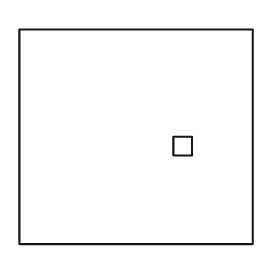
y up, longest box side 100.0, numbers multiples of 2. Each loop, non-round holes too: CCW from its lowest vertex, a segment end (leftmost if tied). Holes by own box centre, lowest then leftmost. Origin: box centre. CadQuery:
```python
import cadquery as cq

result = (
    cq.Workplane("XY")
    .moveTo(-50.0, -46.0)
    .lineTo(50.0, -46.0)
    .lineTo(50.0, 46.0)
    .lineTo(-50.0, 46.0)
    .close()
    .moveTo(16.0, -8.0)
    .lineTo(24.0, -8.0)
    .lineTo(24.0, 0.0)
    .lineTo(16.0, 0.0)
    .close()
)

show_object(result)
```